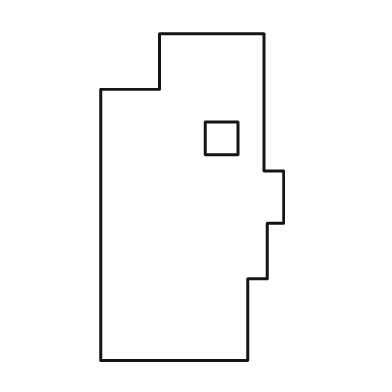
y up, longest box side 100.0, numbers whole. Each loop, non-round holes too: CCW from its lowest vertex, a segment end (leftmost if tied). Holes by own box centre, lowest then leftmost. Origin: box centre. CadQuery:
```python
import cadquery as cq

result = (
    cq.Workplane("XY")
    .moveTo(-28.0, -50.0)
    .lineTo(17.0, -50.0)
    .lineTo(17.0, -25.0)
    .lineTo(23.0, -25.0)
    .lineTo(23.0, -8.0)
    .lineTo(28.0, -8.0)
    .lineTo(28.0, 8.0)
    .lineTo(22.0, 8.0)
    .lineTo(22.0, 50.0)
    .lineTo(-10.0, 50.0)
    .lineTo(-10.0, 33.0)
    .lineTo(-28.0, 33.0)
    .close()
    .moveTo(4.0, 13.0)
    .lineTo(14.0, 13.0)
    .lineTo(14.0, 23.0)
    .lineTo(4.0, 23.0)
    .close()
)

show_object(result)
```